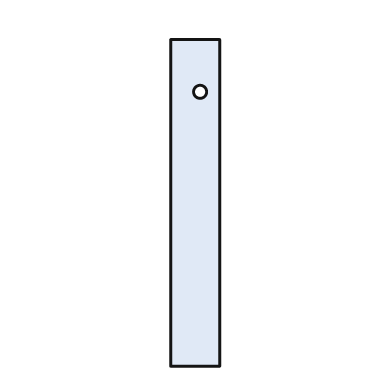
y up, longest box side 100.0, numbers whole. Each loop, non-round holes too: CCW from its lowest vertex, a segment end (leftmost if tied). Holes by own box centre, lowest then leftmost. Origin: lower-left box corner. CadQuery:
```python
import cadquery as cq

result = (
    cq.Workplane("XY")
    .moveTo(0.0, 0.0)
    .lineTo(15.0, 0.0)
    .lineTo(15.0, 100.0)
    .lineTo(0.0, 100.0)
    .close()
    .moveTo(9.0, 84.0)
    .circle(2.0)
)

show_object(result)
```